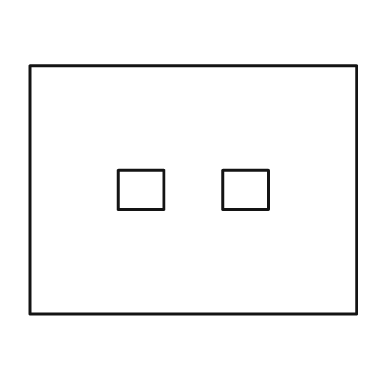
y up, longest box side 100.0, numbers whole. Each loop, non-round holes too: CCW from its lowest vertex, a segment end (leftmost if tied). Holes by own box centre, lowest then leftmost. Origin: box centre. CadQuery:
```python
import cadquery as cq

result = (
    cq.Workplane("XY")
    .moveTo(-50.0, -38.0)
    .lineTo(50.0, -38.0)
    .lineTo(50.0, 38.0)
    .lineTo(-50.0, 38.0)
    .close()
    .moveTo(-23.0, -6.0)
    .lineTo(-9.0, -6.0)
    .lineTo(-9.0, 6.0)
    .lineTo(-23.0, 6.0)
    .close()
    .moveTo(9.0, -6.0)
    .lineTo(23.0, -6.0)
    .lineTo(23.0, 6.0)
    .lineTo(9.0, 6.0)
    .close()
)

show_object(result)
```